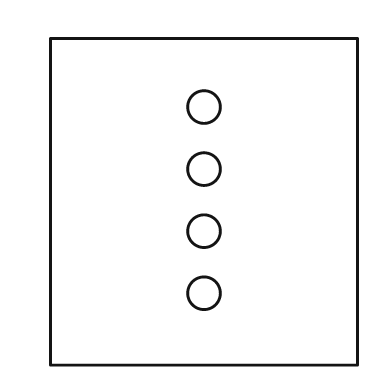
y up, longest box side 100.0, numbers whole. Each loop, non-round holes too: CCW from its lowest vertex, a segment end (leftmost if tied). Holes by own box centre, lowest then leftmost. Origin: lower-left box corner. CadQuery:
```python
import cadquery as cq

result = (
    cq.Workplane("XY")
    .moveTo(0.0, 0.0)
    .lineTo(94.0, 0.0)
    .lineTo(94.0, 100.0)
    .lineTo(0.0, 100.0)
    .close()
    .moveTo(47.0, 22.0)
    .circle(5.0)
    .moveTo(47.0, 41.0)
    .circle(5.0)
    .moveTo(47.0, 60.0)
    .circle(5.0)
    .moveTo(47.0, 79.0)
    .circle(5.0)
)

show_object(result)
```